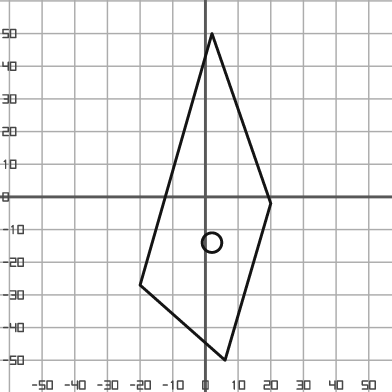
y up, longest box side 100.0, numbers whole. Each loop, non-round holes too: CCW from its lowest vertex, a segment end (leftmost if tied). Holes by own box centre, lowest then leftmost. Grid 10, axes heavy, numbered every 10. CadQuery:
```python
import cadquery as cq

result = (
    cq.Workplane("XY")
    .moveTo(6.0, -50.0)
    .lineTo(20.0, -2.0)
    .lineTo(2.0, 50.0)
    .lineTo(-20.0, -27.0)
    .close()
    .moveTo(2.0, -14.0)
    .circle(3.0)
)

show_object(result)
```